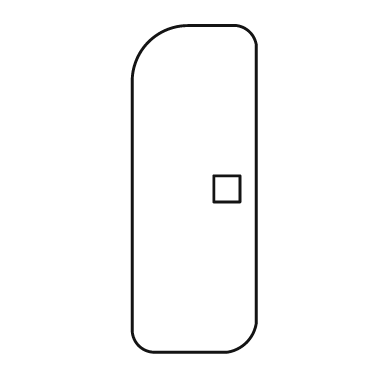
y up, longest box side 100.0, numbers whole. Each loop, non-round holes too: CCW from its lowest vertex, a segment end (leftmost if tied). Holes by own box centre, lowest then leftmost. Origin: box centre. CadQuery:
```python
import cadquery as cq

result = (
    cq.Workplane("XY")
    .moveTo(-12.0, -50.0)
    .lineTo(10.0, -50.0)
    .threePointArc((16.0, -47.0), (19.0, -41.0))
    .lineTo(19.0, 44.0)
    .threePointArc((17.0, 48.0), (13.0, 50.0))
    .lineTo(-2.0, 50.0)
    .threePointArc((-14.0, 45.0), (-19.0, 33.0))
    .lineTo(-19.0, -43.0)
    .threePointArc((-17.0, -48.0), (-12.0, -50.0))
    .close()
    .moveTo(6.0, -4.0)
    .lineTo(14.0, -4.0)
    .lineTo(14.0, 4.0)
    .lineTo(6.0, 4.0)
    .close()
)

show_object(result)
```